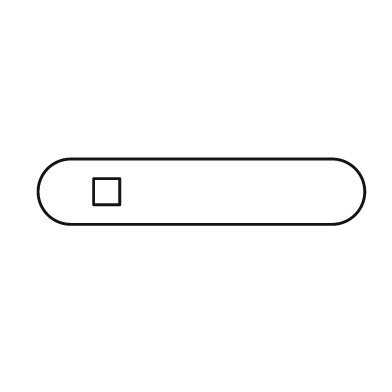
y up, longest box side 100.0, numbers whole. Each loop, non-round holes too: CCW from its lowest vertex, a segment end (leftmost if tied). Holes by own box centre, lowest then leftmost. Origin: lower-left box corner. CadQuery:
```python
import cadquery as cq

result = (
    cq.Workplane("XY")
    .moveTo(10.0, 0.0)
    .lineTo(90.0, 0.0)
    .threePointArc((100.0, 10.0), (90.0, 20.0))
    .lineTo(10.0, 20.0)
    .threePointArc((0.0, 10.0), (10.0, 0.0))
    .close()
    .moveTo(17.0, 6.0)
    .lineTo(25.0, 6.0)
    .lineTo(25.0, 14.0)
    .lineTo(17.0, 14.0)
    .close()
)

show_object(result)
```